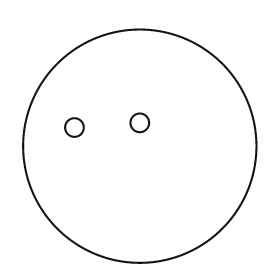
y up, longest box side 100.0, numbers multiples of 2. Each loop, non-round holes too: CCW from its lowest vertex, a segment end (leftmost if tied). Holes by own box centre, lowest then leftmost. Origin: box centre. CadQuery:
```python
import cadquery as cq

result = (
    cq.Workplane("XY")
    .moveTo(0.0, 0.0)
    .circle(50.0)
    .moveTo(-28.0, 8.0)
    .circle(4.0)
    .moveTo(0.0, 10.0)
    .circle(4.0)
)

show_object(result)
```